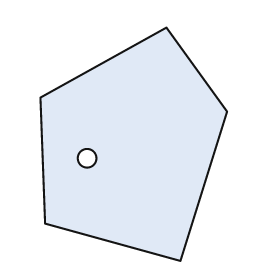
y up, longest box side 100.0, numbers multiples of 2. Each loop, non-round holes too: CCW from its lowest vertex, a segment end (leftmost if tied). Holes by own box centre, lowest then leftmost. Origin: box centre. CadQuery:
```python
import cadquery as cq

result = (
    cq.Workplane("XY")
    .moveTo(20.0, -50.0)
    .lineTo(40.0, 14.0)
    .lineTo(14.0, 50.0)
    .lineTo(-40.0, 20.0)
    .lineTo(-38.0, -34.0)
    .close()
    .moveTo(-20.0, -6.0)
    .circle(4.0)
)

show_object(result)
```